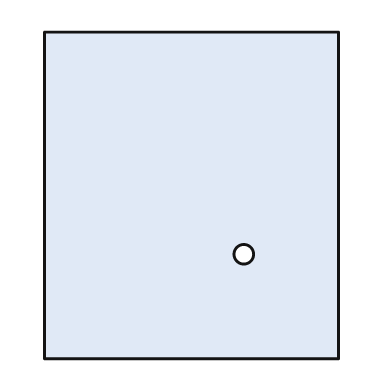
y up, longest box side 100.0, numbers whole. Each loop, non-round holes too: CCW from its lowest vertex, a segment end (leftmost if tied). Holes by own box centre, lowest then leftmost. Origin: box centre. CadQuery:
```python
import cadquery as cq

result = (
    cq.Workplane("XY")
    .moveTo(-45.0, -50.0)
    .lineTo(45.0, -50.0)
    .lineTo(45.0, 50.0)
    .lineTo(-45.0, 50.0)
    .close()
    .moveTo(16.0, -18.0)
    .circle(3.0)
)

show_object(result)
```